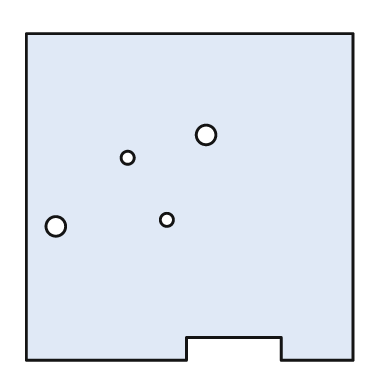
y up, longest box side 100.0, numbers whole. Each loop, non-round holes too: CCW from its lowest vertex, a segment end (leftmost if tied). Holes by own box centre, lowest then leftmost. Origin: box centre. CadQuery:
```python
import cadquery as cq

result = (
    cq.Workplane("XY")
    .moveTo(-50.0, -50.0)
    .lineTo(-1.0, -50.0)
    .lineTo(-1.0, -43.0)
    .lineTo(28.0, -43.0)
    .lineTo(28.0, -50.0)
    .lineTo(50.0, -50.0)
    .lineTo(50.0, 50.0)
    .lineTo(-50.0, 50.0)
    .close()
    .moveTo(-41.0, -9.0)
    .circle(3.0)
    .moveTo(-7.0, -7.0)
    .circle(2.0)
    .moveTo(-19.0, 12.0)
    .circle(2.0)
    .moveTo(5.0, 19.0)
    .circle(3.0)
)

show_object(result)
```